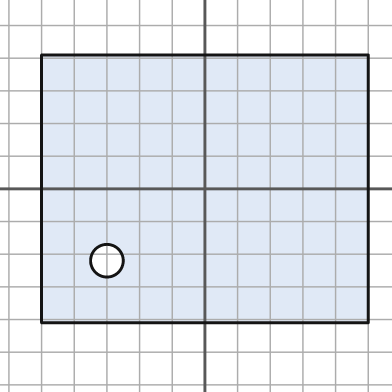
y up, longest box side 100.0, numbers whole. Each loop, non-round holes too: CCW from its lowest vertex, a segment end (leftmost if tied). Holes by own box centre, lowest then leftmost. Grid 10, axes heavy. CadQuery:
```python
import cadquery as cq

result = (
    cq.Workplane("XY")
    .moveTo(-50.0, -41.0)
    .lineTo(50.0, -41.0)
    .lineTo(50.0, 41.0)
    .lineTo(-50.0, 41.0)
    .close()
    .moveTo(-30.0, -22.0)
    .circle(5.0)
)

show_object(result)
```